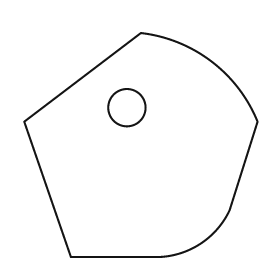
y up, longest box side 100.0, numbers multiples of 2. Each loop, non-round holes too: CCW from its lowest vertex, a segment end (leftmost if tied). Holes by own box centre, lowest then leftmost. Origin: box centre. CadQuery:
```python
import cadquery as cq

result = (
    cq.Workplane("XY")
    .moveTo(-30.0, -48.0)
    .lineTo(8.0, -48.0)
    .threePointArc((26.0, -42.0), (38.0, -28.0))
    .lineTo(50.0, 10.0)
    .threePointArc((30.0, 36.0), (0.0, 48.0))
    .lineTo(-50.0, 10.0)
    .close()
    .moveTo(-6.0, 16.0)
    .circle(8.0)
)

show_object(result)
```